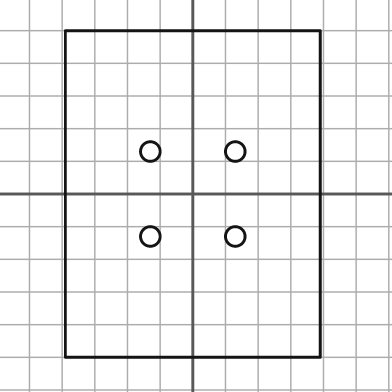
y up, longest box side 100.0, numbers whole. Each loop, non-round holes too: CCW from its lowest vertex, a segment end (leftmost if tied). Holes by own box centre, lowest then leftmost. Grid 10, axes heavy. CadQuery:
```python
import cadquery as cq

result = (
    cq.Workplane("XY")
    .moveTo(-39.0, -50.0)
    .lineTo(39.0, -50.0)
    .lineTo(39.0, 50.0)
    .lineTo(-39.0, 50.0)
    .close()
    .moveTo(-13.0, -13.0)
    .circle(3.0)
    .moveTo(13.0, -13.0)
    .circle(3.0)
    .moveTo(-13.0, 13.0)
    .circle(3.0)
    .moveTo(13.0, 13.0)
    .circle(3.0)
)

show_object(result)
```